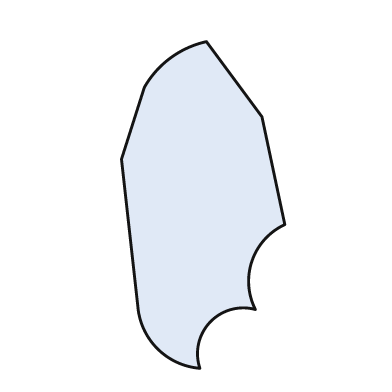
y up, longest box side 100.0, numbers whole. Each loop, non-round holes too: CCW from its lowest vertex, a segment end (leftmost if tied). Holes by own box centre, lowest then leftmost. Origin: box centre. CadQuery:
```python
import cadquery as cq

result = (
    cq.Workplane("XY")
    .moveTo(-1.0, -50.0)
    .threePointArc((2.0, -36.0), (16.0, -32.0))
    .threePointArc((15.0, -17.0), (25.0, -6.0))
    .lineTo(18.0, 27.0)
    .lineTo(1.0, 50.0)
    .threePointArc((-10.0, 45.0), (-18.0, 36.0))
    .lineTo(-25.0, 14.0)
    .lineTo(-20.0, -31.0)
    .threePointArc((-14.0, -44.0), (-1.0, -50.0))
    .close()
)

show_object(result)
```